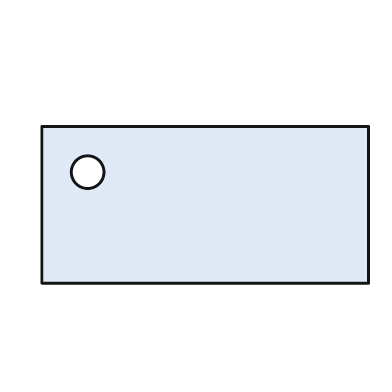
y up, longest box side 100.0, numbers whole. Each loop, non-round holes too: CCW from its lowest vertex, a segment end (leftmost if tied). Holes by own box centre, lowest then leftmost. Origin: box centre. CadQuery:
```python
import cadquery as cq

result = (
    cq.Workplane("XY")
    .moveTo(-50.0, -24.0)
    .lineTo(50.0, -24.0)
    .lineTo(50.0, 24.0)
    .lineTo(-50.0, 24.0)
    .close()
    .moveTo(-36.0, 10.0)
    .circle(5.0)
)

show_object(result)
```